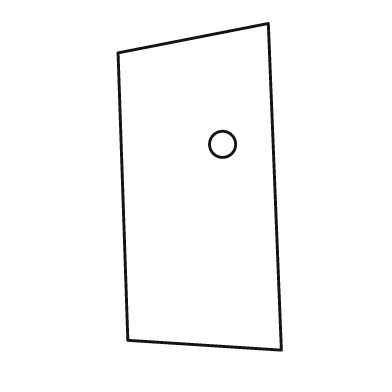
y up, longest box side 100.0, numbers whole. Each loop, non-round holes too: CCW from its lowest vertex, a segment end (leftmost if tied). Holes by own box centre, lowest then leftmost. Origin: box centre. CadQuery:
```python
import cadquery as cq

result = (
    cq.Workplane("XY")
    .moveTo(25.0, -50.0)
    .lineTo(21.0, 50.0)
    .lineTo(-25.0, 41.0)
    .lineTo(-22.0, -47.0)
    .close()
    .moveTo(7.0, 13.0)
    .circle(4.0)
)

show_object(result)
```